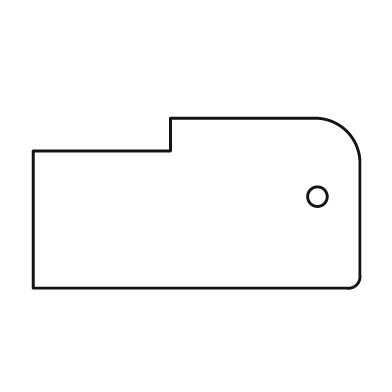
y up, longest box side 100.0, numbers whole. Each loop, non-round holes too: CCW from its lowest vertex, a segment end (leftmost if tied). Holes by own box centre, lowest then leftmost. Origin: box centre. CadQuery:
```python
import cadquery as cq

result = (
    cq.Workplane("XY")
    .moveTo(-50.0, -26.0)
    .lineTo(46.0, -26.0)
    .threePointArc((49.0, -25.0), (50.0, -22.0))
    .lineTo(50.0, 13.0)
    .threePointArc((46.0, 22.0), (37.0, 26.0))
    .lineTo(-8.0, 26.0)
    .lineTo(-8.0, 16.0)
    .lineTo(-50.0, 16.0)
    .close()
    .moveTo(37.0, 2.0)
    .circle(3.0)
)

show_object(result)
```